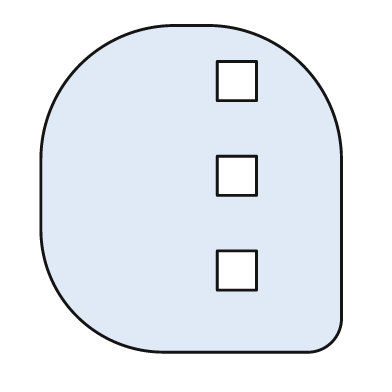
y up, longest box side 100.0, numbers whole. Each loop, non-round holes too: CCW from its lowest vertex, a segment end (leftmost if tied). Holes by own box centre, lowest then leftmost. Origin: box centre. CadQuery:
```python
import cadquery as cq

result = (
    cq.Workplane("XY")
    .moveTo(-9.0, -50.0)
    .lineTo(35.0, -50.0)
    .threePointArc((43.0, -47.0), (46.0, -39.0))
    .lineTo(46.0, 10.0)
    .threePointArc((34.0, 38.0), (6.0, 50.0))
    .lineTo(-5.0, 50.0)
    .threePointArc((-34.0, 38.0), (-46.0, 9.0))
    .lineTo(-46.0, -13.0)
    .threePointArc((-35.0, -39.0), (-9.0, -50.0))
    .close()
    .moveTo(8.0, -31.0)
    .lineTo(20.0, -31.0)
    .lineTo(20.0, -19.0)
    .lineTo(8.0, -19.0)
    .close()
    .moveTo(8.0, -2.0)
    .lineTo(20.0, -2.0)
    .lineTo(20.0, 10.0)
    .lineTo(8.0, 10.0)
    .close()
    .moveTo(8.0, 27.0)
    .lineTo(20.0, 27.0)
    .lineTo(20.0, 39.0)
    .lineTo(8.0, 39.0)
    .close()
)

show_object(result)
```